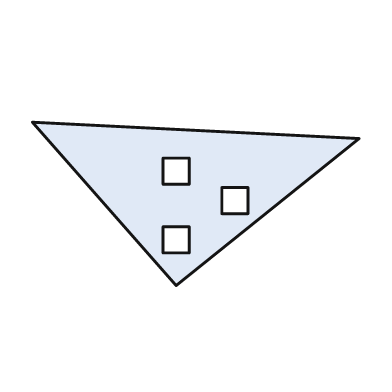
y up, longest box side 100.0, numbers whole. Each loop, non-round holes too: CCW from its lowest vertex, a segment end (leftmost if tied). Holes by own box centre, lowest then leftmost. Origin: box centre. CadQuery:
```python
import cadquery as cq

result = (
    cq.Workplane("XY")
    .moveTo(-6.0, -25.0)
    .lineTo(50.0, 20.0)
    .lineTo(-50.0, 25.0)
    .close()
    .moveTo(-10.0, -15.0)
    .lineTo(-2.0, -15.0)
    .lineTo(-2.0, -7.0)
    .lineTo(-10.0, -7.0)
    .close()
    .moveTo(8.0, -3.0)
    .lineTo(16.0, -3.0)
    .lineTo(16.0, 5.0)
    .lineTo(8.0, 5.0)
    .close()
    .moveTo(-10.0, 6.0)
    .lineTo(-2.0, 6.0)
    .lineTo(-2.0, 14.0)
    .lineTo(-10.0, 14.0)
    .close()
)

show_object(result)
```